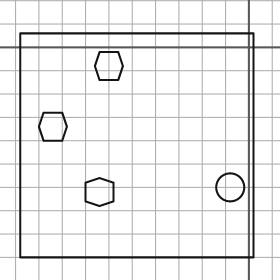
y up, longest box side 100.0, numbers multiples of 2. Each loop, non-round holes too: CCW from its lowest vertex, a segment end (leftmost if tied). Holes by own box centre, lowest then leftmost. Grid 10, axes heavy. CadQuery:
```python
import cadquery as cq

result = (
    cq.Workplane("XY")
    .moveTo(-98.0, -90.0)
    .lineTo(2.0, -90.0)
    .lineTo(2.0, 6.0)
    .lineTo(-98.0, 6.0)
    .close()
    .moveTo(-64.0, -68.0)
    .lineTo(-58.0, -66.0)
    .lineTo(-58.0, -58.0)
    .lineTo(-64.0, -56.0)
    .lineTo(-70.0, -58.0)
    .lineTo(-70.0, -66.0)
    .close()
    .moveTo(-8.0, -60.0)
    .circle(6.0)
    .moveTo(-88.0, -40.0)
    .lineTo(-80.0, -40.0)
    .lineTo(-78.0, -34.0)
    .lineTo(-80.0, -28.0)
    .lineTo(-88.0, -28.0)
    .lineTo(-90.0, -34.0)
    .close()
    .moveTo(-64.0, -14.0)
    .lineTo(-56.0, -14.0)
    .lineTo(-54.0, -8.0)
    .lineTo(-56.0, -2.0)
    .lineTo(-64.0, -2.0)
    .lineTo(-66.0, -8.0)
    .close()
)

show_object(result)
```